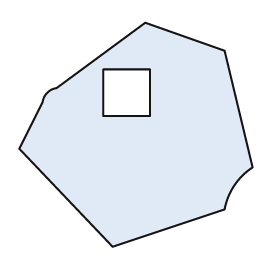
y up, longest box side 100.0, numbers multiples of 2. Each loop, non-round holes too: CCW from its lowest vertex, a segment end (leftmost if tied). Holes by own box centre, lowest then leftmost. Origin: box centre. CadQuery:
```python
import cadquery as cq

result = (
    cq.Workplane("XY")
    .moveTo(-10.0, -48.0)
    .lineTo(38.0, -32.0)
    .threePointArc((42.0, -22.0), (50.0, -14.0))
    .lineTo(38.0, 36.0)
    .lineTo(4.0, 48.0)
    .lineTo(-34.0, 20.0)
    .threePointArc((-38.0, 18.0), (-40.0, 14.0))
    .lineTo(-50.0, -6.0)
    .close()
    .moveTo(-14.0, 8.0)
    .lineTo(6.0, 8.0)
    .lineTo(6.0, 28.0)
    .lineTo(-14.0, 28.0)
    .close()
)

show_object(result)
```